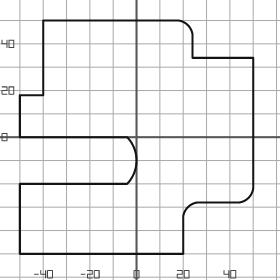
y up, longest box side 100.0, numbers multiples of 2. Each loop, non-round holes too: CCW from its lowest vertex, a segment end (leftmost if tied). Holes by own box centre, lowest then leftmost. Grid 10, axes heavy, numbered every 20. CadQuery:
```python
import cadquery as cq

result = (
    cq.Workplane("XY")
    .moveTo(-50.0, -50.0)
    .lineTo(20.0, -50.0)
    .lineTo(20.0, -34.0)
    .threePointArc((22.0, -30.0), (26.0, -28.0))
    .lineTo(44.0, -28.0)
    .threePointArc((48.0, -26.0), (50.0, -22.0))
    .lineTo(50.0, 34.0)
    .lineTo(24.0, 34.0)
    .lineTo(24.0, 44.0)
    .threePointArc((22.0, 48.0), (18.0, 50.0))
    .lineTo(-40.0, 50.0)
    .lineTo(-40.0, 18.0)
    .lineTo(-50.0, 18.0)
    .lineTo(-50.0, 0.0)
    .lineTo(-4.0, 0.0)
    .threePointArc((0.0, -10.0), (-4.0, -20.0))
    .lineTo(-50.0, -20.0)
    .close()
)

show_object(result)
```